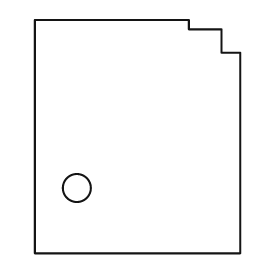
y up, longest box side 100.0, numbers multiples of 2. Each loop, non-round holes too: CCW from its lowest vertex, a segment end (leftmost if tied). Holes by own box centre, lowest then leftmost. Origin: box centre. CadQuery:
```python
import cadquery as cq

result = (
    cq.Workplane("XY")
    .moveTo(-44.0, -50.0)
    .lineTo(44.0, -50.0)
    .lineTo(44.0, 36.0)
    .lineTo(36.0, 36.0)
    .lineTo(36.0, 46.0)
    .lineTo(22.0, 46.0)
    .lineTo(22.0, 50.0)
    .lineTo(-44.0, 50.0)
    .close()
    .moveTo(-26.0, -22.0)
    .circle(6.0)
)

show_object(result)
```